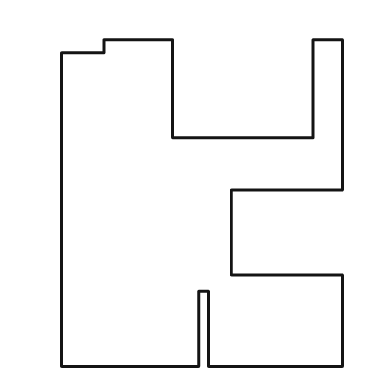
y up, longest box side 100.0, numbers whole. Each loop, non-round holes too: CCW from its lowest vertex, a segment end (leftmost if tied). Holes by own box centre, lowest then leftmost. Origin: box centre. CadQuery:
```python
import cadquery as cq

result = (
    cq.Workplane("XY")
    .moveTo(-43.0, -50.0)
    .lineTo(-1.0, -50.0)
    .lineTo(-1.0, -27.0)
    .lineTo(2.0, -27.0)
    .lineTo(2.0, -50.0)
    .lineTo(43.0, -50.0)
    .lineTo(43.0, -22.0)
    .lineTo(9.0, -22.0)
    .lineTo(9.0, 4.0)
    .lineTo(43.0, 4.0)
    .lineTo(43.0, 50.0)
    .lineTo(34.0, 50.0)
    .lineTo(34.0, 20.0)
    .lineTo(-9.0, 20.0)
    .lineTo(-9.0, 50.0)
    .lineTo(-30.0, 50.0)
    .lineTo(-30.0, 46.0)
    .lineTo(-43.0, 46.0)
    .close()
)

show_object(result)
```